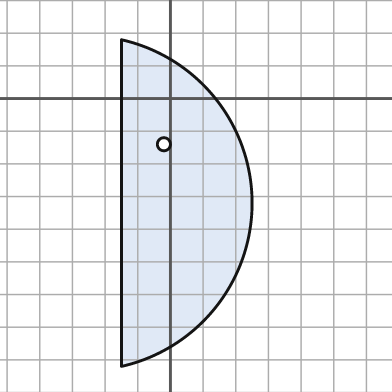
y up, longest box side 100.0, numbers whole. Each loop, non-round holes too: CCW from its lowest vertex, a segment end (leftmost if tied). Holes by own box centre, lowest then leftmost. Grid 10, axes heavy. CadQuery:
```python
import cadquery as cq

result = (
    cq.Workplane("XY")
    .moveTo(-15.0, -82.0)
    .threePointArc((25.0, -32.0), (-15.0, 18.0))
    .close()
    .moveTo(-2.0, -14.0)
    .circle(2.0)
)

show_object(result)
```